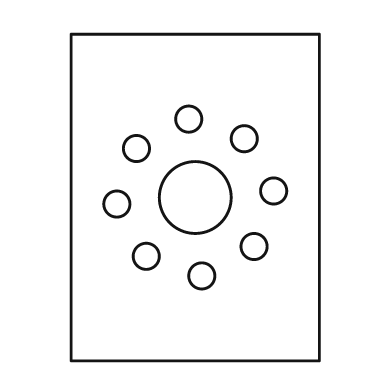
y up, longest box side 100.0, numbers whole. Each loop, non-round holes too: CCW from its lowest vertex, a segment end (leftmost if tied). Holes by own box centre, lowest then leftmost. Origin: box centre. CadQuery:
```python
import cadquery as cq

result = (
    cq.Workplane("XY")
    .moveTo(-38.0, -50.0)
    .lineTo(38.0, -50.0)
    .lineTo(38.0, 50.0)
    .lineTo(-38.0, 50.0)
    .close()
    .moveTo(2.0, -24.0)
    .circle(4.0)
    .moveTo(-15.0, -18.0)
    .circle(4.0)
    .moveTo(18.0, -15.0)
    .circle(4.0)
    .moveTo(-24.0, -2.0)
    .circle(4.0)
    .moveTo(0.0, 0.0)
    .circle(11.0)
    .moveTo(24.0, 2.0)
    .circle(4.0)
    .moveTo(-18.0, 15.0)
    .circle(4.0)
    .moveTo(15.0, 18.0)
    .circle(4.0)
    .moveTo(-2.0, 24.0)
    .circle(4.0)
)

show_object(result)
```